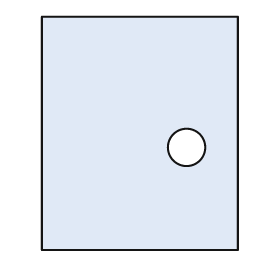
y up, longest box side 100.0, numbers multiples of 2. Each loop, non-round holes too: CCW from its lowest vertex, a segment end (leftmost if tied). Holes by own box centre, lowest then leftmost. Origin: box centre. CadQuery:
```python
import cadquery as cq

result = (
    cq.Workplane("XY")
    .moveTo(-42.0, -50.0)
    .lineTo(42.0, -50.0)
    .lineTo(42.0, 50.0)
    .lineTo(-42.0, 50.0)
    .close()
    .moveTo(20.0, -6.0)
    .circle(8.0)
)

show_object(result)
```